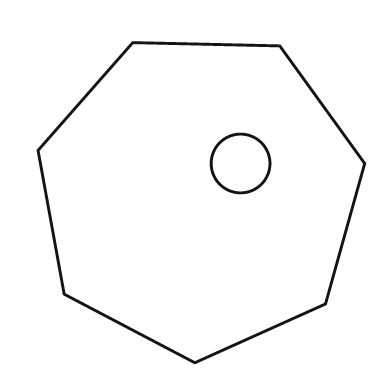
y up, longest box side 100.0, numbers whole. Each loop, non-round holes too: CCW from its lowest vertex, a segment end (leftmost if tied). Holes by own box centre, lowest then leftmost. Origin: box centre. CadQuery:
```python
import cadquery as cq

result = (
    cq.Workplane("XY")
    .moveTo(-2.0, -49.0)
    .lineTo(38.0, -31.0)
    .lineTo(50.0, 12.0)
    .lineTo(24.0, 48.0)
    .lineTo(-21.0, 49.0)
    .lineTo(-50.0, 16.0)
    .lineTo(-42.0, -28.0)
    .close()
    .moveTo(12.0, 12.0)
    .circle(9.0)
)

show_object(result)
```